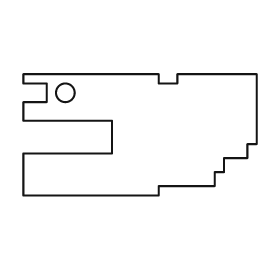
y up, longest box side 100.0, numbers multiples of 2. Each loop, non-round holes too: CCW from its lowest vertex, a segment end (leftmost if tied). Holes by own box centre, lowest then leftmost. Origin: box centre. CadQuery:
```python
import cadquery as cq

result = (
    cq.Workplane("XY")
    .moveTo(-50.0, -26.0)
    .lineTo(8.0, -26.0)
    .lineTo(8.0, -22.0)
    .lineTo(32.0, -22.0)
    .lineTo(32.0, -16.0)
    .lineTo(36.0, -16.0)
    .lineTo(36.0, -10.0)
    .lineTo(46.0, -10.0)
    .lineTo(46.0, -4.0)
    .lineTo(50.0, -4.0)
    .lineTo(50.0, 26.0)
    .lineTo(16.0, 26.0)
    .lineTo(16.0, 22.0)
    .lineTo(8.0, 22.0)
    .lineTo(8.0, 26.0)
    .lineTo(-50.0, 26.0)
    .lineTo(-50.0, 22.0)
    .lineTo(-40.0, 22.0)
    .lineTo(-40.0, 14.0)
    .lineTo(-50.0, 14.0)
    .lineTo(-50.0, 6.0)
    .lineTo(-12.0, 6.0)
    .lineTo(-12.0, -8.0)
    .lineTo(-50.0, -8.0)
    .close()
    .moveTo(-32.0, 18.0)
    .circle(4.0)
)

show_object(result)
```